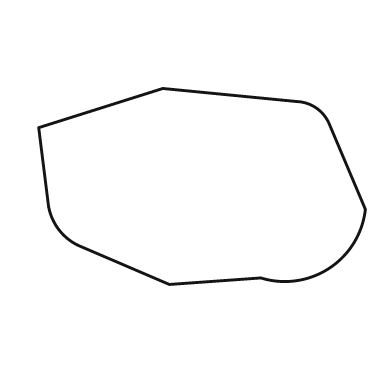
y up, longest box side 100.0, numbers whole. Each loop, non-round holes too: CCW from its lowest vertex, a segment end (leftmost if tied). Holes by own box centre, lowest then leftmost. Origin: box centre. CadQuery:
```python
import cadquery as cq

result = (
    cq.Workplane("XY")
    .moveTo(-10.0, -30.0)
    .lineTo(18.0, -28.0)
    .threePointArc((39.0, -25.0), (50.0, -7.0))
    .lineTo(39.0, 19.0)
    .threePointArc((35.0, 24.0), (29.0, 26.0))
    .lineTo(-12.0, 30.0)
    .lineTo(-50.0, 18.0)
    .lineTo(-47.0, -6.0)
    .threePointArc((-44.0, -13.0), (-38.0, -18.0))
    .close()
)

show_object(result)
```